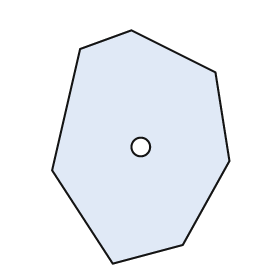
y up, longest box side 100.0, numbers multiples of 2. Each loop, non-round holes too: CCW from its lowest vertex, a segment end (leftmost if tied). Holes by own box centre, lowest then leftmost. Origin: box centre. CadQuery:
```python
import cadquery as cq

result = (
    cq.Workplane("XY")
    .moveTo(-12.0, -50.0)
    .lineTo(18.0, -42.0)
    .lineTo(38.0, -6.0)
    .lineTo(32.0, 32.0)
    .lineTo(-4.0, 50.0)
    .lineTo(-26.0, 42.0)
    .lineTo(-38.0, -10.0)
    .close()
    .moveTo(0.0, 0.0)
    .circle(4.0)
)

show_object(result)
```